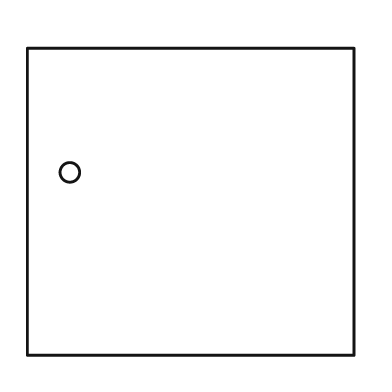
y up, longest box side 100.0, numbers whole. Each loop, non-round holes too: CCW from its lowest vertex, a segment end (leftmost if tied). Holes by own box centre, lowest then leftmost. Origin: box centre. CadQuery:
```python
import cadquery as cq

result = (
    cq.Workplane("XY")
    .moveTo(-50.0, -47.0)
    .lineTo(50.0, -47.0)
    .lineTo(50.0, 47.0)
    .lineTo(-50.0, 47.0)
    .close()
    .moveTo(-37.0, 9.0)
    .circle(3.0)
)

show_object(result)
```